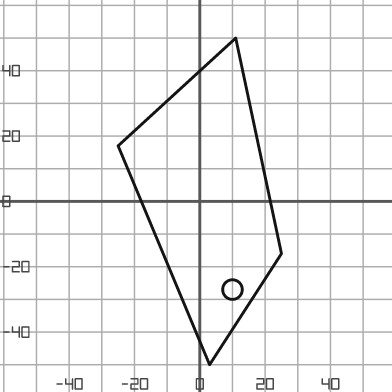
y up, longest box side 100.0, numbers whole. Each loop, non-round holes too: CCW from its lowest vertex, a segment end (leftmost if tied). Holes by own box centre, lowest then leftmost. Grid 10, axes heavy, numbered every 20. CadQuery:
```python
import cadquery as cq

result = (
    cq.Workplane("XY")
    .moveTo(3.0, -50.0)
    .lineTo(25.0, -16.0)
    .lineTo(11.0, 50.0)
    .lineTo(-25.0, 17.0)
    .close()
    .moveTo(10.0, -27.0)
    .circle(3.0)
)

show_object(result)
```